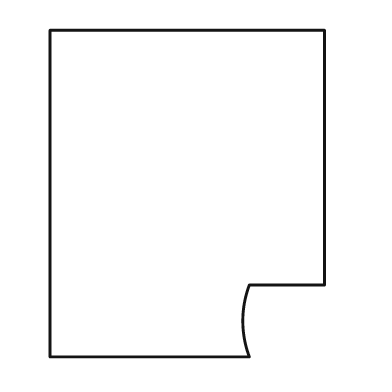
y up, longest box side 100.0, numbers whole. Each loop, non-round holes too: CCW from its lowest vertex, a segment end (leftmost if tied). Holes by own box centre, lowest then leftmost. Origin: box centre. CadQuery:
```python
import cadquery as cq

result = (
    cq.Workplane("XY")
    .moveTo(-42.0, -50.0)
    .lineTo(19.0, -50.0)
    .threePointArc((17.0, -39.0), (19.0, -28.0))
    .lineTo(42.0, -28.0)
    .lineTo(42.0, 50.0)
    .lineTo(-42.0, 50.0)
    .close()
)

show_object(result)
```